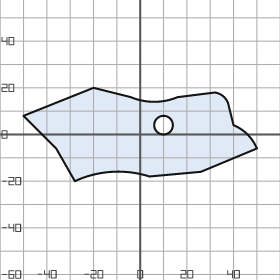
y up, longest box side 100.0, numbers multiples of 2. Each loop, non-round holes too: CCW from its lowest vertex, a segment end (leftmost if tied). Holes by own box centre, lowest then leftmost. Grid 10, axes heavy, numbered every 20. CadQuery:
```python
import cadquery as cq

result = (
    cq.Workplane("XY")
    .moveTo(-28.0, -20.0)
    .threePointArc((-12.0, -16.0), (4.0, -18.0))
    .lineTo(26.0, -16.0)
    .lineTo(50.0, -6.0)
    .threePointArc((46.0, 0.0), (40.0, 4.0))
    .lineTo(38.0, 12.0)
    .threePointArc((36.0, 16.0), (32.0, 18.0))
    .lineTo(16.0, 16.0)
    .threePointArc((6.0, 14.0), (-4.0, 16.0))
    .lineTo(-20.0, 20.0)
    .lineTo(-50.0, 8.0)
    .lineTo(-36.0, -6.0)
    .close()
    .moveTo(10.0, 4.0)
    .circle(4.0)
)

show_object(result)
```